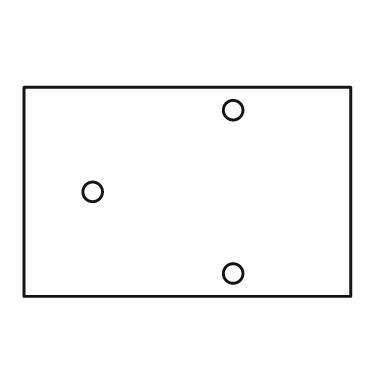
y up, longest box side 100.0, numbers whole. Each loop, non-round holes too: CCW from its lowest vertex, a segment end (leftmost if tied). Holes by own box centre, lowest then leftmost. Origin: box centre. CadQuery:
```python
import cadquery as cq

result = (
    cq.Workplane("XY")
    .moveTo(-50.0, -32.0)
    .lineTo(50.0, -32.0)
    .lineTo(50.0, 32.0)
    .lineTo(-50.0, 32.0)
    .close()
    .moveTo(14.0, -25.0)
    .circle(3.0)
    .moveTo(-29.0, 0.0)
    .circle(3.0)
    .moveTo(14.0, 25.0)
    .circle(3.0)
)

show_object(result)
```